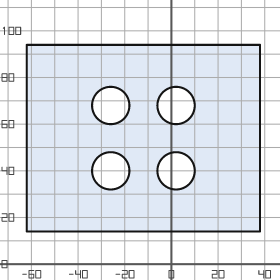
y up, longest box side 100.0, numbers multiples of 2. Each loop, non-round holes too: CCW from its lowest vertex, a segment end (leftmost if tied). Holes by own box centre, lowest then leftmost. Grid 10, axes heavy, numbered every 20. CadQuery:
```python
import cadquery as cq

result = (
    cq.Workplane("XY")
    .moveTo(-62.0, 14.0)
    .lineTo(38.0, 14.0)
    .lineTo(38.0, 94.0)
    .lineTo(-62.0, 94.0)
    .close()
    .moveTo(-26.0, 40.0)
    .circle(8.0)
    .moveTo(2.0, 40.0)
    .circle(8.0)
    .moveTo(-26.0, 68.0)
    .circle(8.0)
    .moveTo(2.0, 68.0)
    .circle(8.0)
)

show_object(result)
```